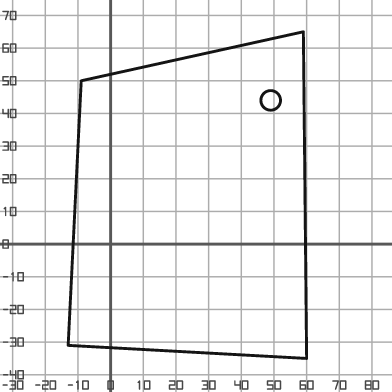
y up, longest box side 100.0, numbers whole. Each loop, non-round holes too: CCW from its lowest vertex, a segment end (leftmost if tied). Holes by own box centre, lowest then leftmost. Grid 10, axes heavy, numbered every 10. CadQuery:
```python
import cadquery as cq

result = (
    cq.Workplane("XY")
    .moveTo(60.0, -35.0)
    .lineTo(59.0, 65.0)
    .lineTo(-9.0, 50.0)
    .lineTo(-13.0, -31.0)
    .close()
    .moveTo(49.0, 44.0)
    .circle(3.0)
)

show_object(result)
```